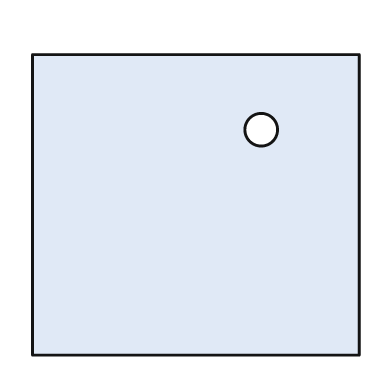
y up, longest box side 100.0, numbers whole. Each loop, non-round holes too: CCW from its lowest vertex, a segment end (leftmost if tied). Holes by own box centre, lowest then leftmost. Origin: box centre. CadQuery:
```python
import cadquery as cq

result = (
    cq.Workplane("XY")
    .moveTo(-50.0, -46.0)
    .lineTo(50.0, -46.0)
    .lineTo(50.0, 46.0)
    .lineTo(-50.0, 46.0)
    .close()
    .moveTo(20.0, 23.0)
    .circle(5.0)
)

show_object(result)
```